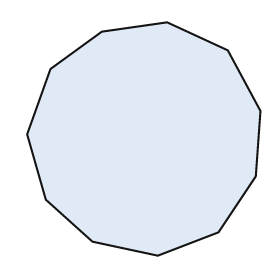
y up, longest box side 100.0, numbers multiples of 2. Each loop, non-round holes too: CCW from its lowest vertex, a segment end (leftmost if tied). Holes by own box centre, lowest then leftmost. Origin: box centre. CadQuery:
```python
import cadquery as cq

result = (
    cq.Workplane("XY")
    .moveTo(6.0, -50.0)
    .lineTo(32.0, -40.0)
    .lineTo(48.0, -16.0)
    .lineTo(50.0, 12.0)
    .lineTo(36.0, 38.0)
    .lineTo(10.0, 50.0)
    .lineTo(-18.0, 46.0)
    .lineTo(-40.0, 30.0)
    .lineTo(-50.0, 2.0)
    .lineTo(-42.0, -26.0)
    .lineTo(-22.0, -44.0)
    .close()
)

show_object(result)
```